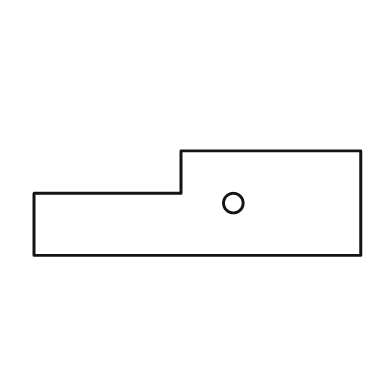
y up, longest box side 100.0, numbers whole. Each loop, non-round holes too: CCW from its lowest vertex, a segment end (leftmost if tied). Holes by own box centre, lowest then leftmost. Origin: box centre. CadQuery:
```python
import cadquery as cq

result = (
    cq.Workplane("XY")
    .moveTo(-50.0, -16.0)
    .lineTo(50.0, -16.0)
    .lineTo(50.0, 16.0)
    .lineTo(-5.0, 16.0)
    .lineTo(-5.0, 3.0)
    .lineTo(-50.0, 3.0)
    .close()
    .moveTo(11.0, 0.0)
    .circle(3.0)
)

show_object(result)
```